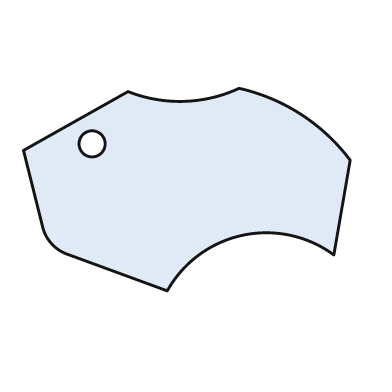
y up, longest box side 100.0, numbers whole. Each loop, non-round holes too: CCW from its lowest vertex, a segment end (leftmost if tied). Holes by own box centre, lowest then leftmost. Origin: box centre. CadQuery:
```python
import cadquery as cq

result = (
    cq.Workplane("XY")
    .moveTo(-6.0, -31.0)
    .threePointArc((17.0, -14.0), (45.0, -20.0))
    .lineTo(50.0, 9.0)
    .threePointArc((35.0, 23.0), (16.0, 31.0))
    .threePointArc((-1.0, 27.0), (-18.0, 30.0))
    .lineTo(-50.0, 12.0)
    .lineTo(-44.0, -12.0)
    .threePointArc((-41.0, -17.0), (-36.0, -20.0))
    .close()
    .moveTo(-29.0, 14.0)
    .circle(4.0)
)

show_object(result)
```